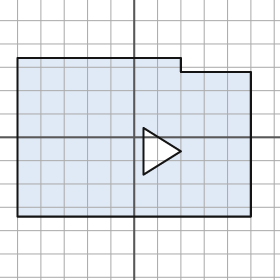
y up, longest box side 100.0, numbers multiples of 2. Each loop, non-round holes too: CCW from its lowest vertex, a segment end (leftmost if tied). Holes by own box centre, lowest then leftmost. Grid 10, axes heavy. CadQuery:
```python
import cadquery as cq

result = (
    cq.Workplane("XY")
    .moveTo(-50.0, -34.0)
    .lineTo(50.0, -34.0)
    .lineTo(50.0, 28.0)
    .lineTo(20.0, 28.0)
    .lineTo(20.0, 34.0)
    .lineTo(-50.0, 34.0)
    .close()
    .moveTo(4.0, -16.0)
    .lineTo(20.0, -6.0)
    .lineTo(4.0, 4.0)
    .close()
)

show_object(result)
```